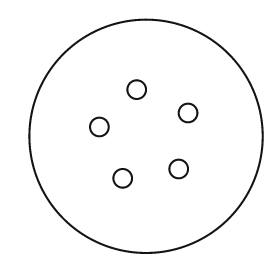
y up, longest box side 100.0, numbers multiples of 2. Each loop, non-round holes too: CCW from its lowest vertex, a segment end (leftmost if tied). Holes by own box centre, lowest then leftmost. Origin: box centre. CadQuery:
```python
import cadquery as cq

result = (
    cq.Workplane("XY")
    .moveTo(0.0, 0.0)
    .circle(50.0)
    .moveTo(-10.0, -18.0)
    .circle(4.0)
    .moveTo(14.0, -14.0)
    .circle(4.0)
    .moveTo(-20.0, 4.0)
    .circle(4.0)
    .moveTo(18.0, 10.0)
    .circle(4.0)
    .moveTo(-4.0, 20.0)
    .circle(4.0)
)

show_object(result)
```